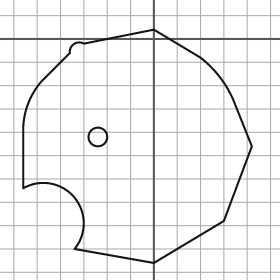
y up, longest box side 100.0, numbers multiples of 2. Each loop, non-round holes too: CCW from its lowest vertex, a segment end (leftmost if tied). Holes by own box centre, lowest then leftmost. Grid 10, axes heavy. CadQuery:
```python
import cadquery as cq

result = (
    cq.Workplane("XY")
    .moveTo(0.0, -96.0)
    .lineTo(30.0, -78.0)
    .lineTo(42.0, -46.0)
    .lineTo(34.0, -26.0)
    .threePointArc((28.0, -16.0), (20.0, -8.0))
    .lineTo(0.0, 4.0)
    .lineTo(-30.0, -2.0)
    .threePointArc((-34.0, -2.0), (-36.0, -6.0))
    .lineTo(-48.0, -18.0)
    .threePointArc((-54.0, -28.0), (-56.0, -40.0))
    .lineTo(-56.0, -64.0)
    .threePointArc((-34.0, -68.0), (-34.0, -90.0))
    .close()
    .moveTo(-24.0, -42.0)
    .circle(4.0)
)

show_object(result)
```